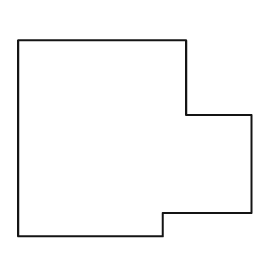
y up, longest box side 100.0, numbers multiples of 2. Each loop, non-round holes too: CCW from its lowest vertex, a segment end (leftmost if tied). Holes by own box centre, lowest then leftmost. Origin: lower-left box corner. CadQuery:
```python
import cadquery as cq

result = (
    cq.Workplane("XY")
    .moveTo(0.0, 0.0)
    .lineTo(62.0, 0.0)
    .lineTo(62.0, 10.0)
    .lineTo(100.0, 10.0)
    .lineTo(100.0, 52.0)
    .lineTo(72.0, 52.0)
    .lineTo(72.0, 84.0)
    .lineTo(0.0, 84.0)
    .close()
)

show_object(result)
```